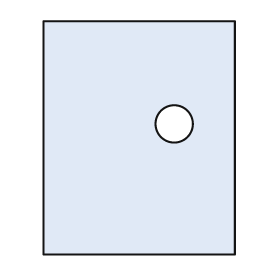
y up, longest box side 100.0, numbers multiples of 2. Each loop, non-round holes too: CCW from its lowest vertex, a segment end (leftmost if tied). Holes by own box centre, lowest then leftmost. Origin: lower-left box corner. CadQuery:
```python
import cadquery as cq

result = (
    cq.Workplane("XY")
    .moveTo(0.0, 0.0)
    .lineTo(82.0, 0.0)
    .lineTo(82.0, 100.0)
    .lineTo(0.0, 100.0)
    .close()
    .moveTo(56.0, 56.0)
    .circle(8.0)
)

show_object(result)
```